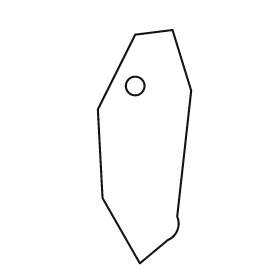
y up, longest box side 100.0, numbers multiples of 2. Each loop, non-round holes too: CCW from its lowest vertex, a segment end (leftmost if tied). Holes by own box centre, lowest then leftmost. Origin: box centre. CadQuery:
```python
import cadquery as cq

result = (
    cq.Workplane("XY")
    .moveTo(-2.0, -50.0)
    .lineTo(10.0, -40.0)
    .threePointArc((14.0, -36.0), (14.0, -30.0))
    .lineTo(20.0, 24.0)
    .lineTo(12.0, 50.0)
    .lineTo(-4.0, 48.0)
    .lineTo(-20.0, 16.0)
    .lineTo(-18.0, -22.0)
    .close()
    .moveTo(-4.0, 26.0)
    .circle(4.0)
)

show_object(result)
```